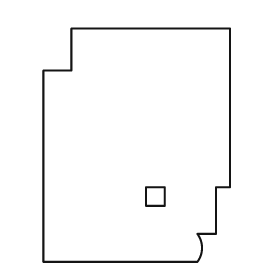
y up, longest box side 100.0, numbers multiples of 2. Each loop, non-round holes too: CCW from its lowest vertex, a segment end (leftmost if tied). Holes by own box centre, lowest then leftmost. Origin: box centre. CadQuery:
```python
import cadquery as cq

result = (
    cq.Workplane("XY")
    .moveTo(-40.0, -50.0)
    .lineTo(26.0, -50.0)
    .threePointArc((28.0, -44.0), (26.0, -38.0))
    .lineTo(34.0, -38.0)
    .lineTo(34.0, -18.0)
    .lineTo(40.0, -18.0)
    .lineTo(40.0, 50.0)
    .lineTo(-28.0, 50.0)
    .lineTo(-28.0, 32.0)
    .lineTo(-40.0, 32.0)
    .close()
    .moveTo(4.0, -26.0)
    .lineTo(12.0, -26.0)
    .lineTo(12.0, -18.0)
    .lineTo(4.0, -18.0)
    .close()
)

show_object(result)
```